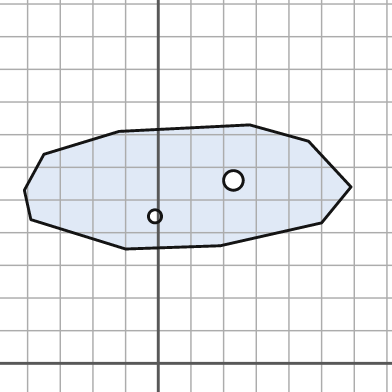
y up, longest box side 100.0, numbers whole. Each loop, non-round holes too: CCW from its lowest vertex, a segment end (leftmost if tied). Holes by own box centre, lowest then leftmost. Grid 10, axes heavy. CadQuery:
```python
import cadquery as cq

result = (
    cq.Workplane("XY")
    .moveTo(-10.0, 35.0)
    .lineTo(19.0, 36.0)
    .lineTo(50.0, 43.0)
    .lineTo(59.0, 54.0)
    .lineTo(46.0, 68.0)
    .lineTo(28.0, 73.0)
    .lineTo(-12.0, 71.0)
    .lineTo(-35.0, 64.0)
    .lineTo(-41.0, 53.0)
    .lineTo(-39.0, 44.0)
    .close()
    .moveTo(-1.0, 45.0)
    .circle(2.0)
    .moveTo(23.0, 56.0)
    .circle(3.0)
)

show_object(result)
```